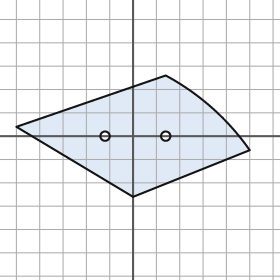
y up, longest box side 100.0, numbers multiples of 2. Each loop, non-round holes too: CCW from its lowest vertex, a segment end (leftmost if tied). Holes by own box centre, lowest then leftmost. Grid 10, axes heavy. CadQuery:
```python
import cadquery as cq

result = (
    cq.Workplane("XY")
    .moveTo(0.0, -26.0)
    .lineTo(50.0, -6.0)
    .threePointArc((34.0, 12.0), (14.0, 26.0))
    .lineTo(-50.0, 4.0)
    .close()
    .moveTo(-12.0, 0.0)
    .circle(2.0)
    .moveTo(14.0, 0.0)
    .circle(2.0)
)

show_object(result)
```